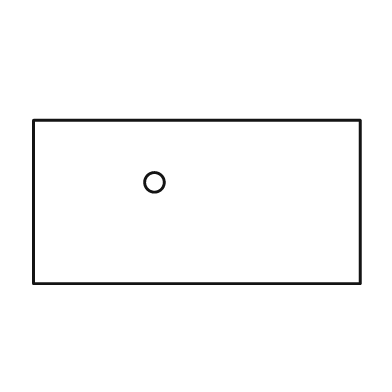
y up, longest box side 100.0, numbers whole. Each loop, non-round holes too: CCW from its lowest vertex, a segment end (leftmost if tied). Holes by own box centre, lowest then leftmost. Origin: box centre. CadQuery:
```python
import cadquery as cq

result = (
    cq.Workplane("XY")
    .moveTo(-50.0, -25.0)
    .lineTo(50.0, -25.0)
    .lineTo(50.0, 25.0)
    .lineTo(-50.0, 25.0)
    .close()
    .moveTo(-13.0, 6.0)
    .circle(3.0)
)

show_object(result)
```